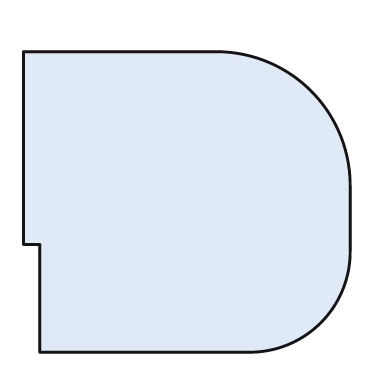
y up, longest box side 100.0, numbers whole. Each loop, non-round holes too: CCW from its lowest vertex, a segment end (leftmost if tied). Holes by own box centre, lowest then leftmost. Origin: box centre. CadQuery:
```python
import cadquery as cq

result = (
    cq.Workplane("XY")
    .moveTo(-45.0, -46.0)
    .lineTo(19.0, -46.0)
    .threePointArc((41.0, -37.0), (50.0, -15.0))
    .lineTo(50.0, 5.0)
    .threePointArc((38.0, 34.0), (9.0, 46.0))
    .lineTo(-50.0, 46.0)
    .lineTo(-50.0, -13.0)
    .lineTo(-45.0, -13.0)
    .close()
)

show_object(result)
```